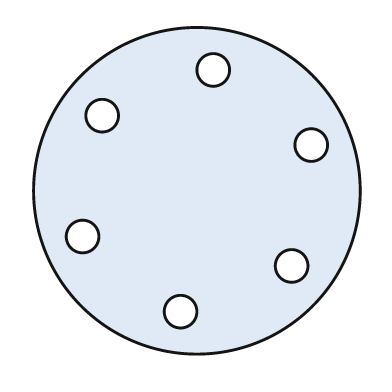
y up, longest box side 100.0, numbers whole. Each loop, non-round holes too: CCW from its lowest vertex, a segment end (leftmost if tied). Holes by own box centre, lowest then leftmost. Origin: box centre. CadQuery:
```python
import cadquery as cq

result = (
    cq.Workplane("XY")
    .moveTo(0.0, 0.0)
    .circle(50.0)
    .moveTo(-5.0, -37.0)
    .circle(5.0)
    .moveTo(29.0, -23.0)
    .circle(5.0)
    .moveTo(-35.0, -14.0)
    .circle(5.0)
    .moveTo(35.0, 14.0)
    .circle(5.0)
    .moveTo(-29.0, 23.0)
    .circle(5.0)
    .moveTo(5.0, 37.0)
    .circle(5.0)
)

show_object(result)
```